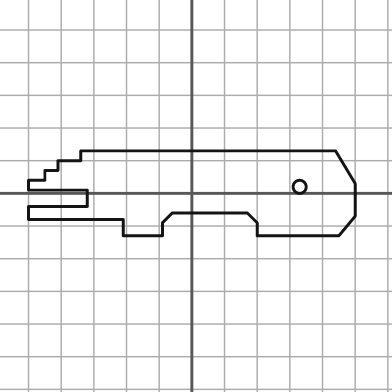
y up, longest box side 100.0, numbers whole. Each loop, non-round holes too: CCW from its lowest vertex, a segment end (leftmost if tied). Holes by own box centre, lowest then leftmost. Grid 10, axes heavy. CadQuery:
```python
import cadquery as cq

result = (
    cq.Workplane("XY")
    .moveTo(-21.0, -13.0)
    .lineTo(-9.0, -13.0)
    .lineTo(-9.0, -9.0)
    .lineTo(-6.0, -6.0)
    .lineTo(17.0, -6.0)
    .lineTo(20.0, -9.0)
    .lineTo(20.0, -13.0)
    .lineTo(45.0, -13.0)
    .lineTo(50.0, -7.0)
    .lineTo(50.0, 3.0)
    .lineTo(44.0, 13.0)
    .lineTo(-34.0, 13.0)
    .lineTo(-34.0, 10.0)
    .lineTo(-41.0, 10.0)
    .lineTo(-41.0, 7.0)
    .lineTo(-45.0, 7.0)
    .lineTo(-45.0, 4.0)
    .lineTo(-50.0, 4.0)
    .lineTo(-50.0, 1.0)
    .lineTo(-32.0, 1.0)
    .lineTo(-32.0, -4.0)
    .lineTo(-50.0, -4.0)
    .lineTo(-50.0, -8.0)
    .lineTo(-21.0, -8.0)
    .close()
    .moveTo(33.0, 2.0)
    .circle(2.0)
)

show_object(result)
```